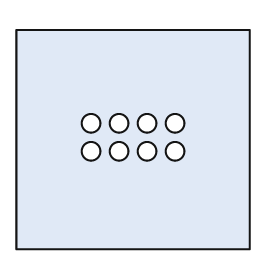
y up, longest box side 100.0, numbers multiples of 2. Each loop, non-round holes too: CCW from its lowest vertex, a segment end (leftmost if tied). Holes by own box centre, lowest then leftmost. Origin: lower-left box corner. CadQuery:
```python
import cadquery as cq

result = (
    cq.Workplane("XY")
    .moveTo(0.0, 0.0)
    .lineTo(100.0, 0.0)
    .lineTo(100.0, 94.0)
    .lineTo(0.0, 94.0)
    .close()
    .moveTo(32.0, 42.0)
    .circle(4.0)
    .moveTo(44.0, 42.0)
    .circle(4.0)
    .moveTo(56.0, 42.0)
    .circle(4.0)
    .moveTo(68.0, 42.0)
    .circle(4.0)
    .moveTo(32.0, 54.0)
    .circle(4.0)
    .moveTo(44.0, 54.0)
    .circle(4.0)
    .moveTo(56.0, 54.0)
    .circle(4.0)
    .moveTo(68.0, 54.0)
    .circle(4.0)
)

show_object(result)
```